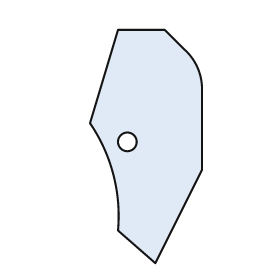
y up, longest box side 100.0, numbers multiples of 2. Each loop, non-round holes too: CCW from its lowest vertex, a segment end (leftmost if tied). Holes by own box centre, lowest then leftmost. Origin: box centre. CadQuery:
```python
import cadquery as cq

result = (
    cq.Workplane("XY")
    .moveTo(4.0, -50.0)
    .lineTo(24.0, -10.0)
    .lineTo(24.0, 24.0)
    .threePointArc((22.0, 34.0), (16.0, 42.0))
    .lineTo(8.0, 50.0)
    .lineTo(-12.0, 50.0)
    .lineTo(-24.0, 10.0)
    .threePointArc((-14.0, -12.0), (-12.0, -36.0))
    .close()
    .moveTo(-8.0, 2.0)
    .circle(4.0)
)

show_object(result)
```